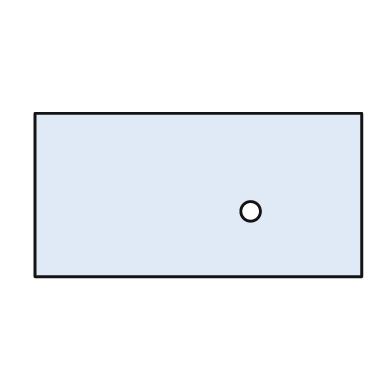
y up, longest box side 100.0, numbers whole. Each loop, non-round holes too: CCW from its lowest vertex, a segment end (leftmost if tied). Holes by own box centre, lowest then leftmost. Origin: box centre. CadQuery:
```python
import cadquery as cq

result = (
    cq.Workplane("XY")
    .moveTo(-50.0, -25.0)
    .lineTo(50.0, -25.0)
    .lineTo(50.0, 25.0)
    .lineTo(-50.0, 25.0)
    .close()
    .moveTo(16.0, -5.0)
    .circle(3.0)
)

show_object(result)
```